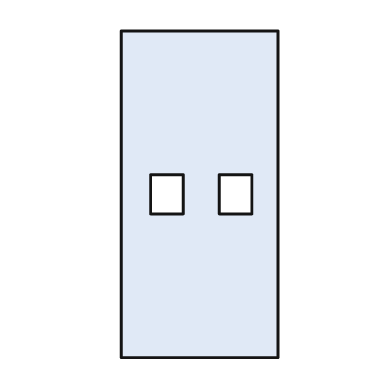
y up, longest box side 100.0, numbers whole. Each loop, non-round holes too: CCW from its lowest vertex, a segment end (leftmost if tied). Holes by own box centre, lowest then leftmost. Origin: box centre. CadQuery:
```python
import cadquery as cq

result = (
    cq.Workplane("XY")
    .moveTo(-24.0, -50.0)
    .lineTo(24.0, -50.0)
    .lineTo(24.0, 50.0)
    .lineTo(-24.0, 50.0)
    .close()
    .moveTo(-15.0, -6.0)
    .lineTo(-5.0, -6.0)
    .lineTo(-5.0, 6.0)
    .lineTo(-15.0, 6.0)
    .close()
    .moveTo(6.0, -6.0)
    .lineTo(16.0, -6.0)
    .lineTo(16.0, 6.0)
    .lineTo(6.0, 6.0)
    .close()
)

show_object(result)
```